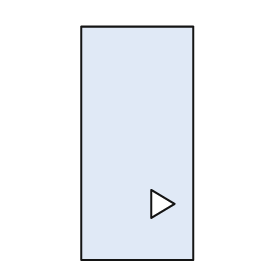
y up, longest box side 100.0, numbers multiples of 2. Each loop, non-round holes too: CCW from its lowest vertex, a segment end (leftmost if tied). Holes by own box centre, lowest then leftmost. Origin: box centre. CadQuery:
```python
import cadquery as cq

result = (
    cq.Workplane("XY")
    .moveTo(-24.0, -50.0)
    .lineTo(24.0, -50.0)
    .lineTo(24.0, 50.0)
    .lineTo(-24.0, 50.0)
    .close()
    .moveTo(6.0, -32.0)
    .lineTo(16.0, -26.0)
    .lineTo(6.0, -20.0)
    .close()
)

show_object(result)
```